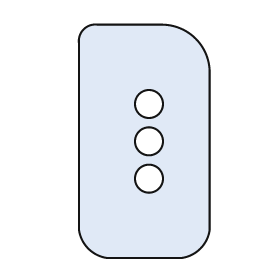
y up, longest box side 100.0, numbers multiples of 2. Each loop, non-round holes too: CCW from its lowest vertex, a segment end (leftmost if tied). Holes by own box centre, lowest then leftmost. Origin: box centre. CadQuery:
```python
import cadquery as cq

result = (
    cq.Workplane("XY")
    .moveTo(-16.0, -50.0)
    .lineTo(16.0, -50.0)
    .threePointArc((24.0, -46.0), (28.0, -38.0))
    .lineTo(28.0, 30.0)
    .threePointArc((22.0, 44.0), (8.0, 50.0))
    .lineTo(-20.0, 50.0)
    .threePointArc((-26.0, 48.0), (-28.0, 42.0))
    .lineTo(-28.0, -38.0)
    .threePointArc((-24.0, -46.0), (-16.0, -50.0))
    .close()
    .moveTo(2.0, -16.0)
    .circle(6.0)
    .moveTo(2.0, 0.0)
    .circle(6.0)
    .moveTo(2.0, 16.0)
    .circle(6.0)
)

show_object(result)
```